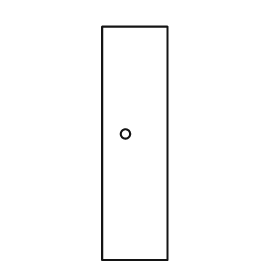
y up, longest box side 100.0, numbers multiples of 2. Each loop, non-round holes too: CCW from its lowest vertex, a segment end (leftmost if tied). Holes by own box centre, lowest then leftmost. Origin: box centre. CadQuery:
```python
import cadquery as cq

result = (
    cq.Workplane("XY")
    .moveTo(-14.0, -50.0)
    .lineTo(14.0, -50.0)
    .lineTo(14.0, 50.0)
    .lineTo(-14.0, 50.0)
    .close()
    .moveTo(-4.0, 4.0)
    .circle(2.0)
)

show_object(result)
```